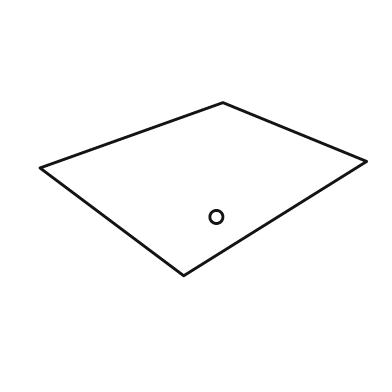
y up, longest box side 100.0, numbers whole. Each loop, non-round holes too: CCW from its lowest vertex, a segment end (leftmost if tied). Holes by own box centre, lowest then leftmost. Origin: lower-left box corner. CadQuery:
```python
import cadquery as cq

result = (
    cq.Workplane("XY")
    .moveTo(44.0, 0.0)
    .lineTo(100.0, 35.0)
    .lineTo(56.0, 53.0)
    .lineTo(0.0, 33.0)
    .close()
    .moveTo(54.0, 18.0)
    .circle(2.0)
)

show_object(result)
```